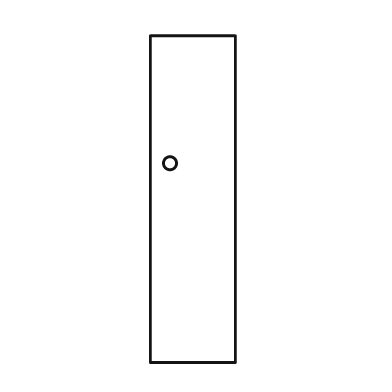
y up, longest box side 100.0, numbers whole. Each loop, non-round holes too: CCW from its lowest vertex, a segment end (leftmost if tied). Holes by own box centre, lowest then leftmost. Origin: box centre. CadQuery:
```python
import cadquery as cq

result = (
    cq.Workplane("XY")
    .moveTo(-13.0, -50.0)
    .lineTo(13.0, -50.0)
    .lineTo(13.0, 50.0)
    .lineTo(-13.0, 50.0)
    .close()
    .moveTo(-7.0, 11.0)
    .circle(2.0)
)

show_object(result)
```